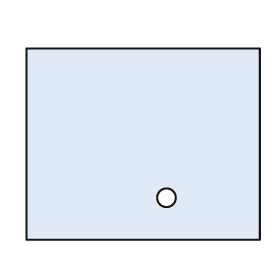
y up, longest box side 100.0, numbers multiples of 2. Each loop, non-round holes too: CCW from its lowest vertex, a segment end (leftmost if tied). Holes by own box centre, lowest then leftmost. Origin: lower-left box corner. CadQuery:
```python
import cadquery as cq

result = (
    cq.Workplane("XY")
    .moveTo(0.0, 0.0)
    .lineTo(100.0, 0.0)
    .lineTo(100.0, 82.0)
    .lineTo(0.0, 82.0)
    .close()
    .moveTo(60.0, 18.0)
    .circle(4.0)
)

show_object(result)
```